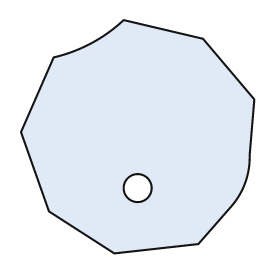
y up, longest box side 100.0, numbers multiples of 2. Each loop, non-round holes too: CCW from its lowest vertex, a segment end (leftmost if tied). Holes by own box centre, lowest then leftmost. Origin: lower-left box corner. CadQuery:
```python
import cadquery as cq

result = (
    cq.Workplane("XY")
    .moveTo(40.0, 0.0)
    .lineTo(76.0, 4.0)
    .lineTo(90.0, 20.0)
    .threePointArc((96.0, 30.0), (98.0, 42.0))
    .lineTo(100.0, 66.0)
    .lineTo(78.0, 92.0)
    .lineTo(44.0, 100.0)
    .threePointArc((30.0, 90.0), (14.0, 84.0))
    .lineTo(0.0, 52.0)
    .lineTo(12.0, 18.0)
    .close()
    .moveTo(50.0, 28.0)
    .circle(6.0)
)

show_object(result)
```